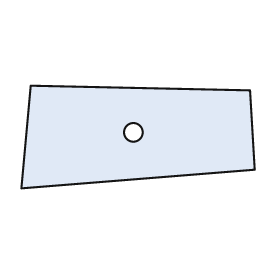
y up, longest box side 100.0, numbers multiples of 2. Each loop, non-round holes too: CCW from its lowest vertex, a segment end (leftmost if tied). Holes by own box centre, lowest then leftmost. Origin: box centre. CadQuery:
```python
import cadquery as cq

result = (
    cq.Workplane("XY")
    .moveTo(-50.0, -22.0)
    .lineTo(50.0, -14.0)
    .lineTo(48.0, 20.0)
    .lineTo(-46.0, 22.0)
    .close()
    .moveTo(-2.0, 2.0)
    .circle(4.0)
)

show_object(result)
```